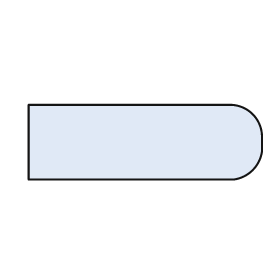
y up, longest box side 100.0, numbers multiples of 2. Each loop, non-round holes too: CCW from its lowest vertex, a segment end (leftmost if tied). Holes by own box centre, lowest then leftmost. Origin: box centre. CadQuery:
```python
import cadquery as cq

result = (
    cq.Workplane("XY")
    .moveTo(-50.0, -16.0)
    .lineTo(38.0, -16.0)
    .threePointArc((46.0, -12.0), (50.0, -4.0))
    .lineTo(50.0, 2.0)
    .threePointArc((46.0, 12.0), (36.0, 16.0))
    .lineTo(-50.0, 16.0)
    .close()
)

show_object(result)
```